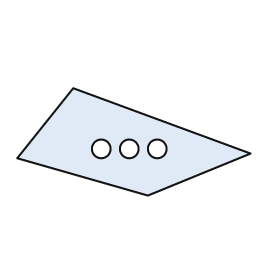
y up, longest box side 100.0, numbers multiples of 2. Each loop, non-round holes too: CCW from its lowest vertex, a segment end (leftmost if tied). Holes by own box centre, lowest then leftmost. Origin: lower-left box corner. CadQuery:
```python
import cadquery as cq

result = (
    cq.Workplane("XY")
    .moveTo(56.0, 0.0)
    .lineTo(100.0, 18.0)
    .lineTo(24.0, 46.0)
    .lineTo(0.0, 16.0)
    .close()
    .moveTo(36.0, 20.0)
    .circle(4.0)
    .moveTo(48.0, 20.0)
    .circle(4.0)
    .moveTo(60.0, 20.0)
    .circle(4.0)
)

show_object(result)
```